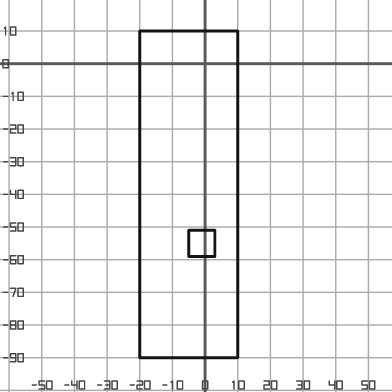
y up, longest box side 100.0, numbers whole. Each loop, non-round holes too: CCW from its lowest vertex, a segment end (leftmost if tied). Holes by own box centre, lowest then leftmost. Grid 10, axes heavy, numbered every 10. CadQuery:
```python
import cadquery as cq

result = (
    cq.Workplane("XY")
    .moveTo(-20.0, -90.0)
    .lineTo(10.0, -90.0)
    .lineTo(10.0, 10.0)
    .lineTo(-20.0, 10.0)
    .close()
    .moveTo(-5.0, -59.0)
    .lineTo(3.0, -59.0)
    .lineTo(3.0, -51.0)
    .lineTo(-5.0, -51.0)
    .close()
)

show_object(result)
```